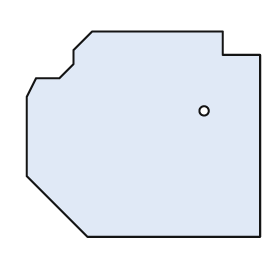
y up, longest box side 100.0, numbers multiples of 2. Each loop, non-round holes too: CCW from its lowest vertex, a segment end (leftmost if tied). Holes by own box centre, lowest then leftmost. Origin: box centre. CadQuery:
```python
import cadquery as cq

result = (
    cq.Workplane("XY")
    .moveTo(-24.0, -44.0)
    .lineTo(50.0, -44.0)
    .lineTo(50.0, 34.0)
    .lineTo(34.0, 34.0)
    .lineTo(34.0, 44.0)
    .lineTo(-22.0, 44.0)
    .lineTo(-30.0, 36.0)
    .lineTo(-30.0, 30.0)
    .lineTo(-36.0, 24.0)
    .lineTo(-46.0, 24.0)
    .lineTo(-50.0, 16.0)
    .lineTo(-50.0, -18.0)
    .close()
    .moveTo(26.0, 10.0)
    .circle(2.0)
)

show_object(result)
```